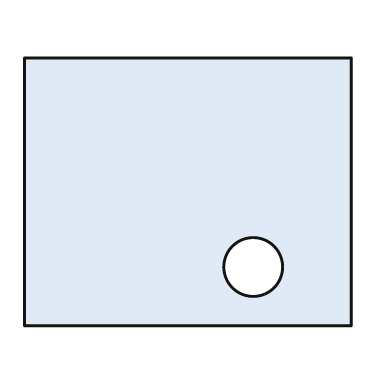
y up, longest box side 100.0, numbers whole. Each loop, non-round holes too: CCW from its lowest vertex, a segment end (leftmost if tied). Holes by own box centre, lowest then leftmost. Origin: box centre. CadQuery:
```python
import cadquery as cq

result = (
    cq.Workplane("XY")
    .moveTo(-50.0, -41.0)
    .lineTo(50.0, -41.0)
    .lineTo(50.0, 41.0)
    .lineTo(-50.0, 41.0)
    .close()
    .moveTo(20.0, -23.0)
    .circle(9.0)
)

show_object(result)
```